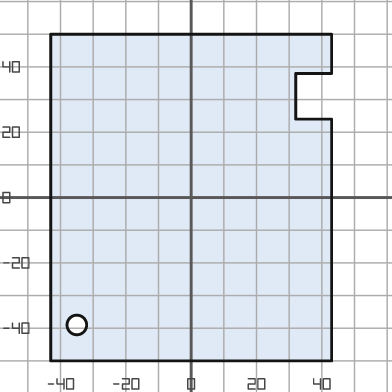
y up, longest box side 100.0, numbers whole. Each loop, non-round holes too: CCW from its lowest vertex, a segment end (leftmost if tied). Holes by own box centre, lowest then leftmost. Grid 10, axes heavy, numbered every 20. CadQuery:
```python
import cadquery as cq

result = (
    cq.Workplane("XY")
    .moveTo(-43.0, -50.0)
    .lineTo(43.0, -50.0)
    .lineTo(43.0, 24.0)
    .lineTo(32.0, 24.0)
    .lineTo(32.0, 38.0)
    .lineTo(43.0, 38.0)
    .lineTo(43.0, 50.0)
    .lineTo(-43.0, 50.0)
    .close()
    .moveTo(-35.0, -39.0)
    .circle(3.0)
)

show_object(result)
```